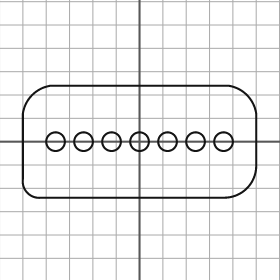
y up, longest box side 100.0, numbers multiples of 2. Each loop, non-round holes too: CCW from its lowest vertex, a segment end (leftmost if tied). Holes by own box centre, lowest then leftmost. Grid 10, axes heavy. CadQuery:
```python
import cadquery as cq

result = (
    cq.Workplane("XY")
    .moveTo(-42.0, -24.0)
    .lineTo(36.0, -24.0)
    .threePointArc((46.0, -20.0), (50.0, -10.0))
    .lineTo(50.0, 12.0)
    .threePointArc((46.0, 20.0), (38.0, 24.0))
    .lineTo(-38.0, 24.0)
    .threePointArc((-46.0, 20.0), (-50.0, 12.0))
    .lineTo(-50.0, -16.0)
    .threePointArc((-48.0, -22.0), (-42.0, -24.0))
    .close()
    .moveTo(-36.0, 0.0)
    .circle(4.0)
    .moveTo(-24.0, 0.0)
    .circle(4.0)
    .moveTo(-12.0, 0.0)
    .circle(4.0)
    .moveTo(0.0, 0.0)
    .circle(4.0)
    .moveTo(12.0, 0.0)
    .circle(4.0)
    .moveTo(24.0, 0.0)
    .circle(4.0)
    .moveTo(36.0, 0.0)
    .circle(4.0)
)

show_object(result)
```